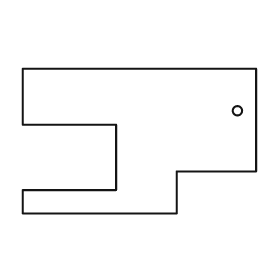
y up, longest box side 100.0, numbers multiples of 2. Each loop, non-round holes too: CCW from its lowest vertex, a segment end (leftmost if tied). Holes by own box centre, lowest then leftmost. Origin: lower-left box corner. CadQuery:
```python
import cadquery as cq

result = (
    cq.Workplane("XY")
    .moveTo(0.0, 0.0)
    .lineTo(66.0, 0.0)
    .lineTo(66.0, 18.0)
    .lineTo(100.0, 18.0)
    .lineTo(100.0, 62.0)
    .lineTo(0.0, 62.0)
    .lineTo(0.0, 38.0)
    .lineTo(40.0, 38.0)
    .lineTo(40.0, 10.0)
    .lineTo(0.0, 10.0)
    .close()
    .moveTo(92.0, 44.0)
    .circle(2.0)
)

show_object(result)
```